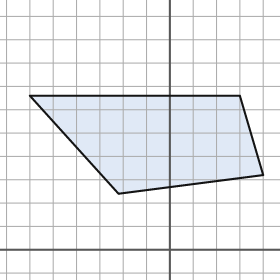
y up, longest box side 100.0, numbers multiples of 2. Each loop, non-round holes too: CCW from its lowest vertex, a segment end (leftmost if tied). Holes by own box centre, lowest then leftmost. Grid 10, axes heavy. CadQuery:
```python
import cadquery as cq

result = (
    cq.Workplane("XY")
    .moveTo(-22.0, 24.0)
    .lineTo(40.0, 32.0)
    .lineTo(30.0, 66.0)
    .lineTo(-60.0, 66.0)
    .close()
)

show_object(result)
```